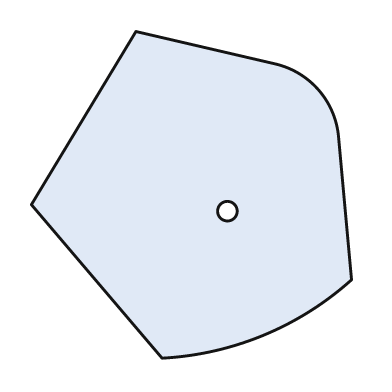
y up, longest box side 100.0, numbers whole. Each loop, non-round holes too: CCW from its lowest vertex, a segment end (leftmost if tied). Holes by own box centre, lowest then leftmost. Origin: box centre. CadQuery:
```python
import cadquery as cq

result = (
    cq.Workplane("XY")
    .moveTo(-9.0, -50.0)
    .threePointArc((22.0, -43.0), (49.0, -26.0))
    .lineTo(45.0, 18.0)
    .threePointArc((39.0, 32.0), (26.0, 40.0))
    .lineTo(-17.0, 50.0)
    .lineTo(-49.0, -3.0)
    .close()
    .moveTo(11.0, -5.0)
    .circle(3.0)
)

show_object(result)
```